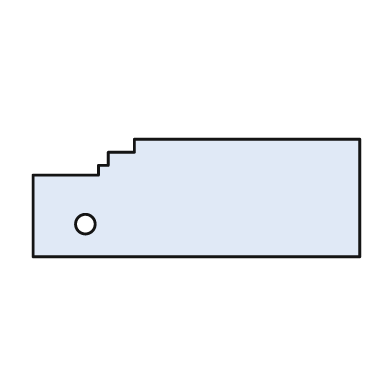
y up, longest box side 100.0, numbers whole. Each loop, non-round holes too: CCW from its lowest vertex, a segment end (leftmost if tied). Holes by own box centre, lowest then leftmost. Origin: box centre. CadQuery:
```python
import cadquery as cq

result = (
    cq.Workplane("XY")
    .moveTo(-50.0, -18.0)
    .lineTo(50.0, -18.0)
    .lineTo(50.0, 18.0)
    .lineTo(-19.0, 18.0)
    .lineTo(-19.0, 14.0)
    .lineTo(-27.0, 14.0)
    .lineTo(-27.0, 10.0)
    .lineTo(-30.0, 10.0)
    .lineTo(-30.0, 7.0)
    .lineTo(-50.0, 7.0)
    .close()
    .moveTo(-34.0, -8.0)
    .circle(3.0)
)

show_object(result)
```